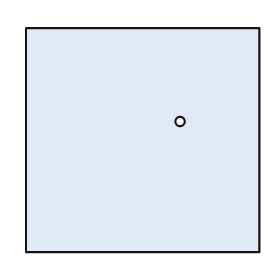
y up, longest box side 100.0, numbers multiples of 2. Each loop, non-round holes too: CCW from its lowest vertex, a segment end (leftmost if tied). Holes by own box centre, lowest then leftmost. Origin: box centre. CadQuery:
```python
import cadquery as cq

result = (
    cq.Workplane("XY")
    .moveTo(-50.0, -48.0)
    .lineTo(50.0, -48.0)
    .lineTo(50.0, 48.0)
    .lineTo(-50.0, 48.0)
    .close()
    .moveTo(16.0, 8.0)
    .circle(2.0)
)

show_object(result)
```